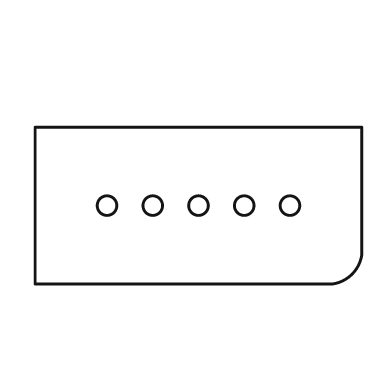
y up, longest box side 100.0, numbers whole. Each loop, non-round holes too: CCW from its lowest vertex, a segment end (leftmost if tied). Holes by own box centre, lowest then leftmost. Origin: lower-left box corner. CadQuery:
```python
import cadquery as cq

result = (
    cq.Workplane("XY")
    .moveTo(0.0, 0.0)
    .lineTo(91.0, 0.0)
    .threePointArc((97.0, 3.0), (100.0, 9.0))
    .lineTo(100.0, 48.0)
    .lineTo(0.0, 48.0)
    .close()
    .moveTo(22.0, 24.0)
    .circle(3.0)
    .moveTo(36.0, 24.0)
    .circle(3.0)
    .moveTo(50.0, 24.0)
    .circle(3.0)
    .moveTo(64.0, 24.0)
    .circle(3.0)
    .moveTo(78.0, 24.0)
    .circle(3.0)
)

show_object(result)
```